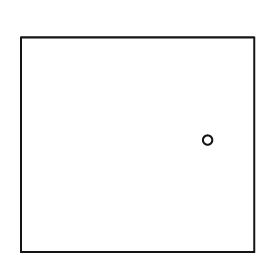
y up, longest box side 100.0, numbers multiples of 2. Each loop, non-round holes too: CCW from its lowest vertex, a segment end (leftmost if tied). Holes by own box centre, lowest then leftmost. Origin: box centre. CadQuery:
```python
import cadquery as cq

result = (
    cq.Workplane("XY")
    .moveTo(-50.0, -46.0)
    .lineTo(50.0, -46.0)
    .lineTo(50.0, 46.0)
    .lineTo(-50.0, 46.0)
    .close()
    .moveTo(30.0, 2.0)
    .circle(2.0)
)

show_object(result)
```